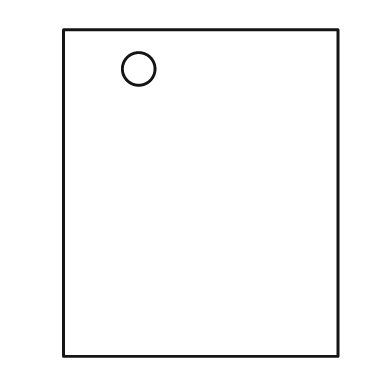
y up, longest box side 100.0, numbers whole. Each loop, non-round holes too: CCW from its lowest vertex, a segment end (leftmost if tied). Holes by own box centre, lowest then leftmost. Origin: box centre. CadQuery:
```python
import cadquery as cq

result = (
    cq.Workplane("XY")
    .moveTo(-42.0, -50.0)
    .lineTo(42.0, -50.0)
    .lineTo(42.0, 50.0)
    .lineTo(-42.0, 50.0)
    .close()
    .moveTo(-19.0, 38.0)
    .circle(5.0)
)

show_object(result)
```